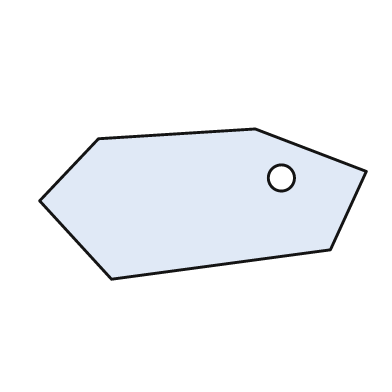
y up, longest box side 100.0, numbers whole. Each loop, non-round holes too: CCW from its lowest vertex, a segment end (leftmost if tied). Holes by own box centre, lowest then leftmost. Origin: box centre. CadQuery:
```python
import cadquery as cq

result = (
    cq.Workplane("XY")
    .moveTo(-28.0, -23.0)
    .lineTo(39.0, -14.0)
    .lineTo(50.0, 10.0)
    .lineTo(16.0, 23.0)
    .lineTo(-32.0, 20.0)
    .lineTo(-50.0, 1.0)
    .close()
    .moveTo(24.0, 8.0)
    .circle(4.0)
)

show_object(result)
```